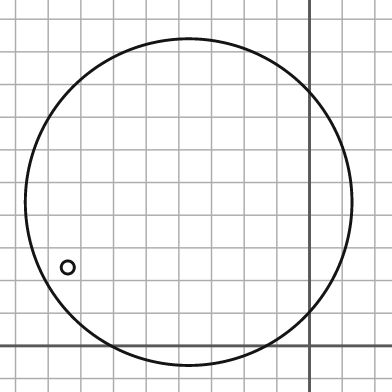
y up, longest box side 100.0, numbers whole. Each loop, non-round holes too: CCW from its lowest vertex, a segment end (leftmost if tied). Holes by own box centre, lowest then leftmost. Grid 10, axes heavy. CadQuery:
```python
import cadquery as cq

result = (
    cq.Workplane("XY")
    .moveTo(-37.0, 44.0)
    .circle(50.0)
    .moveTo(-74.0, 24.0)
    .circle(2.0)
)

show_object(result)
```